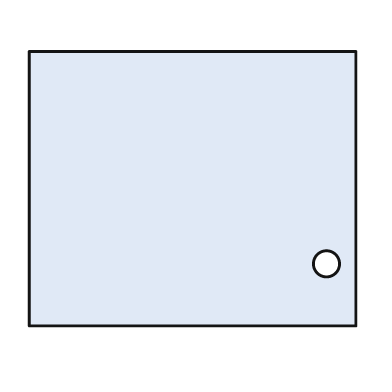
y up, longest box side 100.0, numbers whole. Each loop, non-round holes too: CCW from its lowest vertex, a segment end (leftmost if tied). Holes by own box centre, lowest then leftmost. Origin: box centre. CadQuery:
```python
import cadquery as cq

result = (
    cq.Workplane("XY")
    .moveTo(-50.0, -42.0)
    .lineTo(50.0, -42.0)
    .lineTo(50.0, 42.0)
    .lineTo(-50.0, 42.0)
    .close()
    .moveTo(41.0, -23.0)
    .circle(4.0)
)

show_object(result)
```